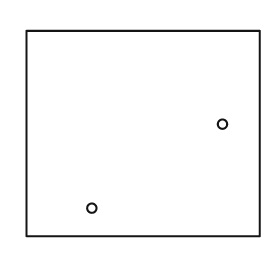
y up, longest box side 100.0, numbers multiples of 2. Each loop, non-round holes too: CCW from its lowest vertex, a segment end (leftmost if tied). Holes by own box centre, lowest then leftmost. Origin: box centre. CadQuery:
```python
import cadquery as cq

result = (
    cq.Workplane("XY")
    .moveTo(-50.0, -44.0)
    .lineTo(50.0, -44.0)
    .lineTo(50.0, 44.0)
    .lineTo(-50.0, 44.0)
    .close()
    .moveTo(-22.0, -32.0)
    .circle(2.0)
    .moveTo(34.0, 4.0)
    .circle(2.0)
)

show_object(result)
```